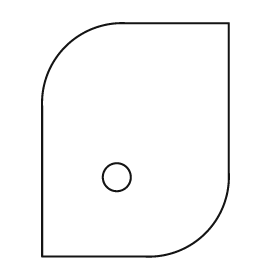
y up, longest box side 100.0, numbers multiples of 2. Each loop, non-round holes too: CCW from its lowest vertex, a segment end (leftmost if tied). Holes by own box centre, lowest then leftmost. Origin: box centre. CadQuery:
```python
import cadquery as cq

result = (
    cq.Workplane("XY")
    .moveTo(-40.0, -50.0)
    .lineTo(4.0, -50.0)
    .threePointArc((30.0, -40.0), (40.0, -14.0))
    .lineTo(40.0, 50.0)
    .lineTo(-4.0, 50.0)
    .threePointArc((-30.0, 40.0), (-40.0, 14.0))
    .close()
    .moveTo(-8.0, -16.0)
    .circle(6.0)
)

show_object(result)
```